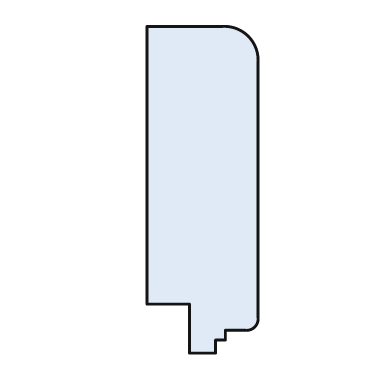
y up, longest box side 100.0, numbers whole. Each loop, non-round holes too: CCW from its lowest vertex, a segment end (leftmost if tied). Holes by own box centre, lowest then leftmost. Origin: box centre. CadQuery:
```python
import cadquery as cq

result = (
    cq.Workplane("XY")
    .moveTo(-4.0, -50.0)
    .lineTo(4.0, -50.0)
    .lineTo(4.0, -46.0)
    .lineTo(7.0, -46.0)
    .lineTo(7.0, -43.0)
    .lineTo(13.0, -43.0)
    .threePointArc((16.0, -42.0), (17.0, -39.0))
    .lineTo(17.0, 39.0)
    .threePointArc((14.0, 47.0), (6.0, 50.0))
    .lineTo(-17.0, 50.0)
    .lineTo(-17.0, -35.0)
    .lineTo(-4.0, -35.0)
    .close()
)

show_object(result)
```